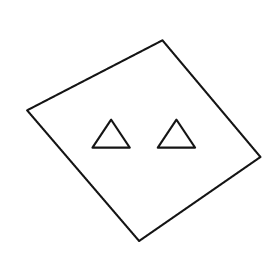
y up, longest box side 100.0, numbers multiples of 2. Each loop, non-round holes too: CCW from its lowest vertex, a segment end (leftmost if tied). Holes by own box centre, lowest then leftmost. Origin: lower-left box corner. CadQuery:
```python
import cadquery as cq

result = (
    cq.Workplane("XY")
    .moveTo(48.0, 0.0)
    .lineTo(100.0, 36.0)
    .lineTo(58.0, 86.0)
    .lineTo(0.0, 56.0)
    .close()
    .moveTo(28.0, 40.0)
    .lineTo(44.0, 40.0)
    .lineTo(36.0, 52.0)
    .close()
    .moveTo(56.0, 40.0)
    .lineTo(72.0, 40.0)
    .lineTo(64.0, 52.0)
    .close()
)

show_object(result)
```